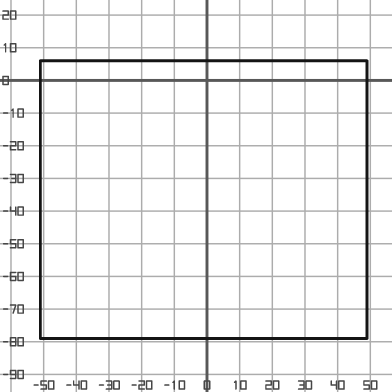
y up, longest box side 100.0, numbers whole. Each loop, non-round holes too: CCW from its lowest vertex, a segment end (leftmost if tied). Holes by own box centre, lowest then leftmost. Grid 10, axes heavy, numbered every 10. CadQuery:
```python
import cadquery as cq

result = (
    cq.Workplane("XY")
    .moveTo(-51.0, -79.0)
    .lineTo(49.0, -79.0)
    .lineTo(49.0, 6.0)
    .lineTo(-51.0, 6.0)
    .close()
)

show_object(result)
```